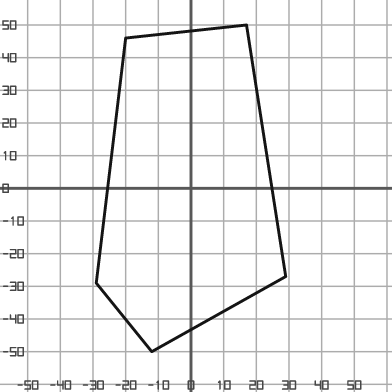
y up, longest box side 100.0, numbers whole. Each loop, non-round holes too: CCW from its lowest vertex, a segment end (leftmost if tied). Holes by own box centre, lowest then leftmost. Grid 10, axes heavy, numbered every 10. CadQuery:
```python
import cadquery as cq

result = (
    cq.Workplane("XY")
    .moveTo(-12.0, -50.0)
    .lineTo(29.0, -27.0)
    .lineTo(17.0, 50.0)
    .lineTo(-20.0, 46.0)
    .lineTo(-29.0, -29.0)
    .close()
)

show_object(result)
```